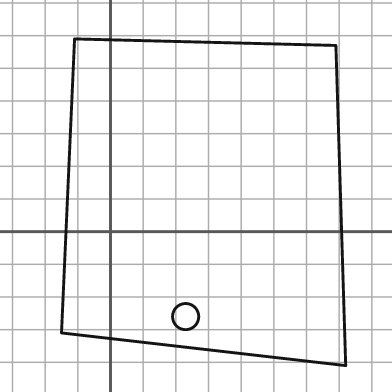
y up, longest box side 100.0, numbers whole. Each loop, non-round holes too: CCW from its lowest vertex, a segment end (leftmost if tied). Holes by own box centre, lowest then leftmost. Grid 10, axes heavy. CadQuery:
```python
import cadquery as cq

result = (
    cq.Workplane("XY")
    .moveTo(72.0, -41.0)
    .lineTo(69.0, 57.0)
    .lineTo(-11.0, 59.0)
    .lineTo(-15.0, -31.0)
    .close()
    .moveTo(23.0, -26.0)
    .circle(4.0)
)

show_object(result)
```